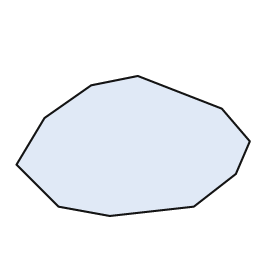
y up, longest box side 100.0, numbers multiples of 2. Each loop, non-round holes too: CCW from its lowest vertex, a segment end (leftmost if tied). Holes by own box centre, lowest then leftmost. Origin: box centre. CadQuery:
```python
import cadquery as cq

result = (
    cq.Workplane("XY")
    .moveTo(-10.0, -30.0)
    .lineTo(26.0, -26.0)
    .lineTo(44.0, -12.0)
    .lineTo(50.0, 2.0)
    .lineTo(38.0, 16.0)
    .lineTo(2.0, 30.0)
    .lineTo(-18.0, 26.0)
    .lineTo(-38.0, 12.0)
    .lineTo(-50.0, -8.0)
    .lineTo(-32.0, -26.0)
    .close()
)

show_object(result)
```